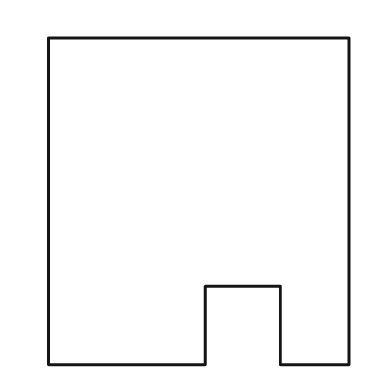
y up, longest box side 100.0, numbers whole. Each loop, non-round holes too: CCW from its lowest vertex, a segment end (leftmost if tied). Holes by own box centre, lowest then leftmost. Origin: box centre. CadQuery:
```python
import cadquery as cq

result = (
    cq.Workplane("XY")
    .moveTo(-46.0, -50.0)
    .lineTo(2.0, -50.0)
    .lineTo(2.0, -26.0)
    .lineTo(25.0, -26.0)
    .lineTo(25.0, -50.0)
    .lineTo(46.0, -50.0)
    .lineTo(46.0, 50.0)
    .lineTo(-46.0, 50.0)
    .close()
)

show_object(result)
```